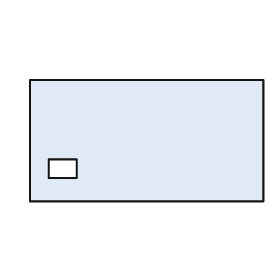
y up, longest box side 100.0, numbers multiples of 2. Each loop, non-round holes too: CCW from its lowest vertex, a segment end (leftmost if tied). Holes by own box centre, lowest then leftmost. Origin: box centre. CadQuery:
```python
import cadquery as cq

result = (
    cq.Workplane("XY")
    .moveTo(-50.0, -26.0)
    .lineTo(50.0, -26.0)
    .lineTo(50.0, 26.0)
    .lineTo(-50.0, 26.0)
    .close()
    .moveTo(-42.0, -16.0)
    .lineTo(-30.0, -16.0)
    .lineTo(-30.0, -8.0)
    .lineTo(-42.0, -8.0)
    .close()
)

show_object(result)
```